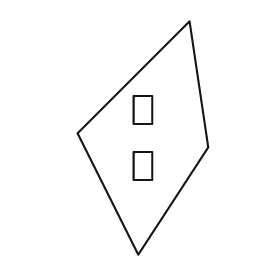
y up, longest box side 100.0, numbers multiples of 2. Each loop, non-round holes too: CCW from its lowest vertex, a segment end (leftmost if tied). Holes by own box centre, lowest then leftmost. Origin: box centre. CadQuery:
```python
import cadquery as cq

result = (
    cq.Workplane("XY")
    .moveTo(-2.0, -50.0)
    .lineTo(28.0, -4.0)
    .lineTo(20.0, 50.0)
    .lineTo(-28.0, 2.0)
    .close()
    .moveTo(-4.0, -18.0)
    .lineTo(4.0, -18.0)
    .lineTo(4.0, -6.0)
    .lineTo(-4.0, -6.0)
    .close()
    .moveTo(-4.0, 6.0)
    .lineTo(4.0, 6.0)
    .lineTo(4.0, 18.0)
    .lineTo(-4.0, 18.0)
    .close()
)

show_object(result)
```